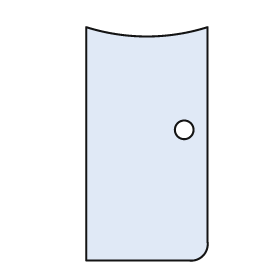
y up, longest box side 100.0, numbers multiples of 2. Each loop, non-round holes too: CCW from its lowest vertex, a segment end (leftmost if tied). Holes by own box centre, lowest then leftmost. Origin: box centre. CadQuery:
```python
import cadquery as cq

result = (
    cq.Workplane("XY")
    .moveTo(-26.0, -50.0)
    .lineTo(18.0, -50.0)
    .threePointArc((24.0, -48.0), (26.0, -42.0))
    .lineTo(26.0, 50.0)
    .threePointArc((0.0, 46.0), (-26.0, 50.0))
    .close()
    .moveTo(16.0, 6.0)
    .circle(4.0)
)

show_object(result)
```